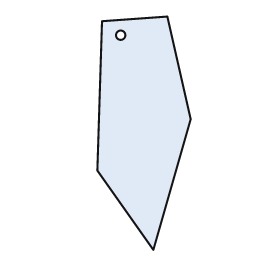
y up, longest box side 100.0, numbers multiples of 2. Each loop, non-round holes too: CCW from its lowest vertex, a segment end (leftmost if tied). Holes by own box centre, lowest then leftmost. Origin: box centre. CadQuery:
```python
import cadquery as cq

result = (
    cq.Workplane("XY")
    .moveTo(4.0, -50.0)
    .lineTo(20.0, 6.0)
    .lineTo(10.0, 50.0)
    .lineTo(-18.0, 48.0)
    .lineTo(-20.0, -16.0)
    .close()
    .moveTo(-10.0, 42.0)
    .circle(2.0)
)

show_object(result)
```